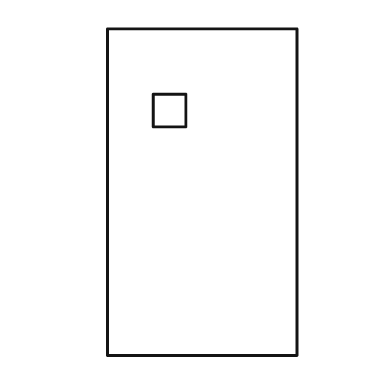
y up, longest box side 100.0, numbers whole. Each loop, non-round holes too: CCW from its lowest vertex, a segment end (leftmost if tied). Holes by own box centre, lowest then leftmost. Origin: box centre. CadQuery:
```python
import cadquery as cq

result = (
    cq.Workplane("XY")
    .moveTo(-29.0, -50.0)
    .lineTo(29.0, -50.0)
    .lineTo(29.0, 50.0)
    .lineTo(-29.0, 50.0)
    .close()
    .moveTo(-15.0, 20.0)
    .lineTo(-5.0, 20.0)
    .lineTo(-5.0, 30.0)
    .lineTo(-15.0, 30.0)
    .close()
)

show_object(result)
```